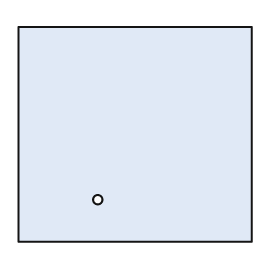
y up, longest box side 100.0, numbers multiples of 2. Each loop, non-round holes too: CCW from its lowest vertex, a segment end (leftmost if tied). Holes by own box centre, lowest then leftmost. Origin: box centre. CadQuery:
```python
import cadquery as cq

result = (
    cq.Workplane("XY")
    .moveTo(-50.0, -46.0)
    .lineTo(50.0, -46.0)
    .lineTo(50.0, 46.0)
    .lineTo(-50.0, 46.0)
    .close()
    .moveTo(-16.0, -28.0)
    .circle(2.0)
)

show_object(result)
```